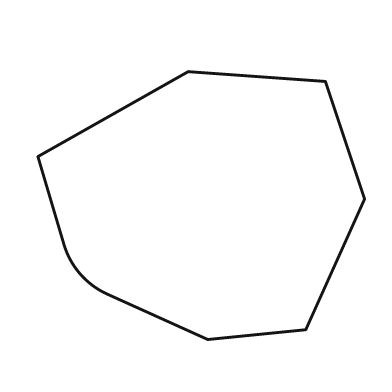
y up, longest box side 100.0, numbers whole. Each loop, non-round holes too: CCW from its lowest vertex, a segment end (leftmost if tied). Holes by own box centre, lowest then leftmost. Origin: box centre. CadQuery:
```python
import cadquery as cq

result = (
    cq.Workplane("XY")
    .moveTo(2.0, -41.0)
    .lineTo(32.0, -38.0)
    .lineTo(50.0, 2.0)
    .lineTo(38.0, 38.0)
    .lineTo(-4.0, 41.0)
    .lineTo(-50.0, 15.0)
    .lineTo(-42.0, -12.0)
    .threePointArc((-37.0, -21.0), (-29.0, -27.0))
    .close()
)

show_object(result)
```